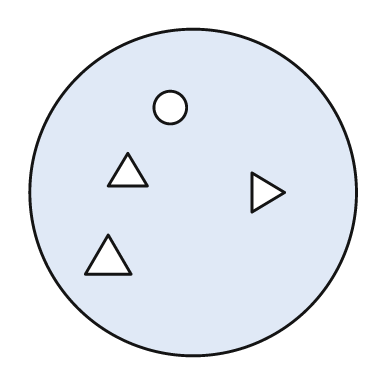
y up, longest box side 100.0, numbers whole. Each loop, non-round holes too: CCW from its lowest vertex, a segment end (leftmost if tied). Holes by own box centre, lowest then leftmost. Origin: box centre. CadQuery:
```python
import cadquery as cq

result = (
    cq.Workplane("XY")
    .moveTo(0.0, 0.0)
    .circle(50.0)
    .moveTo(-33.0, -25.0)
    .lineTo(-19.0, -25.0)
    .lineTo(-26.0, -13.0)
    .close()
    .moveTo(18.0, -6.0)
    .lineTo(28.0, 0.0)
    .lineTo(18.0, 6.0)
    .close()
    .moveTo(-26.0, 2.0)
    .lineTo(-14.0, 2.0)
    .lineTo(-20.0, 12.0)
    .close()
    .moveTo(-7.0, 26.0)
    .circle(5.0)
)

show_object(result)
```